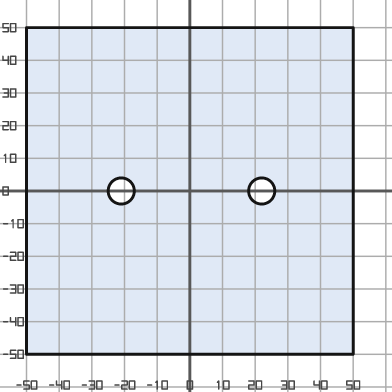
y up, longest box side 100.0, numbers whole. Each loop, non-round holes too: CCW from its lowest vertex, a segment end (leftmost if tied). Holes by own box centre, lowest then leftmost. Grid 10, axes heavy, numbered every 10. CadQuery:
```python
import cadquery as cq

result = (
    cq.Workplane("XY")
    .moveTo(-50.0, -50.0)
    .lineTo(50.0, -50.0)
    .lineTo(50.0, 50.0)
    .lineTo(-50.0, 50.0)
    .close()
    .moveTo(-21.0, 0.0)
    .circle(4.0)
    .moveTo(22.0, 0.0)
    .circle(4.0)
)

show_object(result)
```